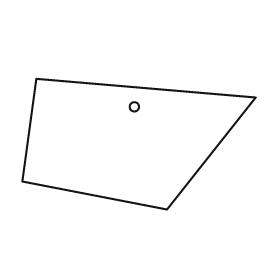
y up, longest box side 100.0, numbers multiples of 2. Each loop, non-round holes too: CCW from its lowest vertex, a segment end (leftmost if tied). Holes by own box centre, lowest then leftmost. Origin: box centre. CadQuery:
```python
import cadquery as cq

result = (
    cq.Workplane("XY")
    .moveTo(12.0, -28.0)
    .lineTo(50.0, 20.0)
    .lineTo(-44.0, 28.0)
    .lineTo(-50.0, -16.0)
    .close()
    .moveTo(-2.0, 16.0)
    .circle(2.0)
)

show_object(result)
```